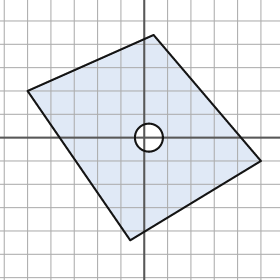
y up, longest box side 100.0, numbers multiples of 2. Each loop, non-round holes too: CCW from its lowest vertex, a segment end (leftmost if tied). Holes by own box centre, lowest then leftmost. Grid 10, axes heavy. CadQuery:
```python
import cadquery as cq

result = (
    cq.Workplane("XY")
    .moveTo(-6.0, -44.0)
    .lineTo(50.0, -10.0)
    .lineTo(4.0, 44.0)
    .lineTo(-50.0, 20.0)
    .close()
    .moveTo(2.0, 0.0)
    .circle(6.0)
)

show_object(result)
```